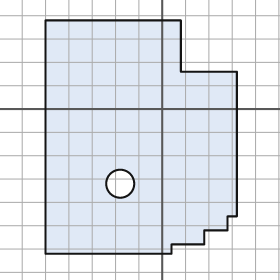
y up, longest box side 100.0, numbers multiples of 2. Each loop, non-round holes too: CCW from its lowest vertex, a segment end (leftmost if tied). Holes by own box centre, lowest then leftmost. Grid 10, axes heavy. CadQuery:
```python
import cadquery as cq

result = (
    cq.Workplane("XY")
    .moveTo(-50.0, -62.0)
    .lineTo(4.0, -62.0)
    .lineTo(4.0, -58.0)
    .lineTo(18.0, -58.0)
    .lineTo(18.0, -52.0)
    .lineTo(28.0, -52.0)
    .lineTo(28.0, -46.0)
    .lineTo(32.0, -46.0)
    .lineTo(32.0, 16.0)
    .lineTo(8.0, 16.0)
    .lineTo(8.0, 38.0)
    .lineTo(-50.0, 38.0)
    .close()
    .moveTo(-18.0, -32.0)
    .circle(6.0)
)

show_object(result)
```